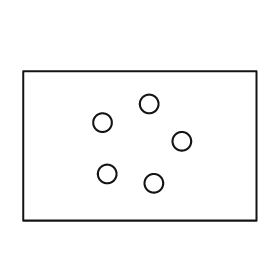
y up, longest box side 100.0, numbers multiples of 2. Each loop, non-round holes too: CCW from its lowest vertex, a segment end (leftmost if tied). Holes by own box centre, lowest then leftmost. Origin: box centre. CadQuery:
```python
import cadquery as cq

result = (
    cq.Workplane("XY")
    .moveTo(-50.0, -32.0)
    .lineTo(50.0, -32.0)
    .lineTo(50.0, 32.0)
    .lineTo(-50.0, 32.0)
    .close()
    .moveTo(6.0, -16.0)
    .circle(4.0)
    .moveTo(-14.0, -12.0)
    .circle(4.0)
    .moveTo(18.0, 2.0)
    .circle(4.0)
    .moveTo(-16.0, 10.0)
    .circle(4.0)
    .moveTo(4.0, 18.0)
    .circle(4.0)
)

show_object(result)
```